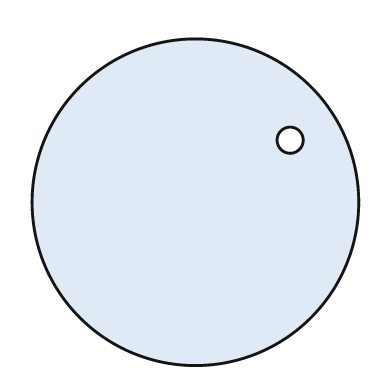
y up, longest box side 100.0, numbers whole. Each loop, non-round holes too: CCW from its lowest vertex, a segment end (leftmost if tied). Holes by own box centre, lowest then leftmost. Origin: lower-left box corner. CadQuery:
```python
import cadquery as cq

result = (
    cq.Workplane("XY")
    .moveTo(50.0, 50.0)
    .circle(50.0)
    .moveTo(79.0, 69.0)
    .circle(4.0)
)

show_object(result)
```